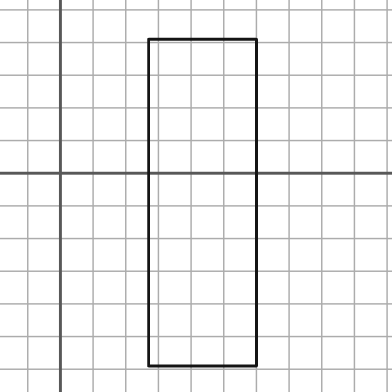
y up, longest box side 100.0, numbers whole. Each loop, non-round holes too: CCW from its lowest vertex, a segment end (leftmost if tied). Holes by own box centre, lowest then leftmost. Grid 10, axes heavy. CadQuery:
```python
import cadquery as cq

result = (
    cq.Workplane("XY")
    .moveTo(27.0, -59.0)
    .lineTo(60.0, -59.0)
    .lineTo(60.0, 41.0)
    .lineTo(27.0, 41.0)
    .close()
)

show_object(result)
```